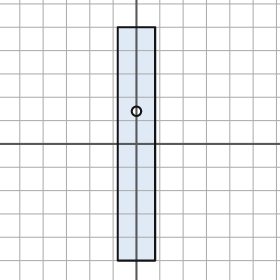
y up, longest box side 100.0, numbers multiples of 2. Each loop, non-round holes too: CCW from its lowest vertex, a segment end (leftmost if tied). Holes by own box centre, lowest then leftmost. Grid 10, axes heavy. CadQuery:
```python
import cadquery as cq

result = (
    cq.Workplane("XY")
    .moveTo(-8.0, -50.0)
    .lineTo(8.0, -50.0)
    .lineTo(8.0, 50.0)
    .lineTo(-8.0, 50.0)
    .close()
    .moveTo(0.0, 14.0)
    .circle(2.0)
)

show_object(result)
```